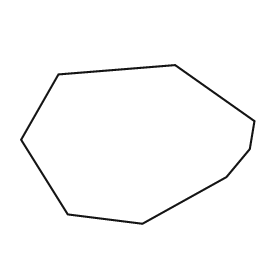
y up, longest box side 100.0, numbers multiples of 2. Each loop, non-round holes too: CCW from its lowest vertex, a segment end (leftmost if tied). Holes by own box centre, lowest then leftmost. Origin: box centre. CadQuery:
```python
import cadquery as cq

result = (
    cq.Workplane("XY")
    .moveTo(2.0, -34.0)
    .lineTo(38.0, -14.0)
    .lineTo(48.0, -2.0)
    .lineTo(50.0, 10.0)
    .lineTo(16.0, 34.0)
    .lineTo(-34.0, 30.0)
    .lineTo(-50.0, 2.0)
    .lineTo(-30.0, -30.0)
    .close()
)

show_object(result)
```